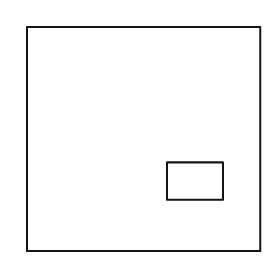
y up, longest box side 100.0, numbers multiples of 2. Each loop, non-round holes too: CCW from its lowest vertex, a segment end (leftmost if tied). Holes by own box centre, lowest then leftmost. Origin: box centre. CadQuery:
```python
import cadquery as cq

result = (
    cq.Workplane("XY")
    .moveTo(-50.0, -48.0)
    .lineTo(50.0, -48.0)
    .lineTo(50.0, 48.0)
    .lineTo(-50.0, 48.0)
    .close()
    .moveTo(10.0, -26.0)
    .lineTo(34.0, -26.0)
    .lineTo(34.0, -10.0)
    .lineTo(10.0, -10.0)
    .close()
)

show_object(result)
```